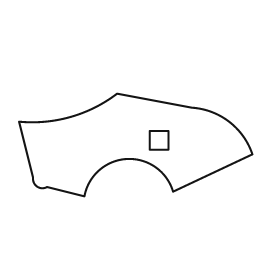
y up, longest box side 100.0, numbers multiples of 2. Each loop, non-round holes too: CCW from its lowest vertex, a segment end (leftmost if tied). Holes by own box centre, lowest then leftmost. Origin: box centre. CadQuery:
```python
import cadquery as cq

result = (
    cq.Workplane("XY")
    .moveTo(-22.0, -22.0)
    .threePointArc((-4.0, -6.0), (16.0, -20.0))
    .lineTo(50.0, -4.0)
    .threePointArc((40.0, 10.0), (24.0, 16.0))
    .lineTo(-8.0, 22.0)
    .threePointArc((-28.0, 12.0), (-50.0, 10.0))
    .lineTo(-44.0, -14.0)
    .threePointArc((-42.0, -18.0), (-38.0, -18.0))
    .close()
    .moveTo(6.0, -2.0)
    .lineTo(14.0, -2.0)
    .lineTo(14.0, 6.0)
    .lineTo(6.0, 6.0)
    .close()
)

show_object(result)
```